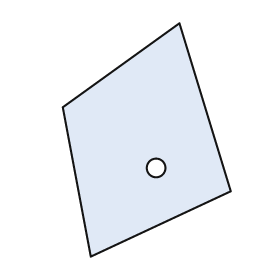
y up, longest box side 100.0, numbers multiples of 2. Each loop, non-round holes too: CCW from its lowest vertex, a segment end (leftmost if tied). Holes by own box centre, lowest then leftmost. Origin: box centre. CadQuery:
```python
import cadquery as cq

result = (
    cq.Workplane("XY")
    .moveTo(-24.0, -50.0)
    .lineTo(36.0, -22.0)
    .lineTo(14.0, 50.0)
    .lineTo(-36.0, 14.0)
    .close()
    .moveTo(4.0, -12.0)
    .circle(4.0)
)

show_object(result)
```